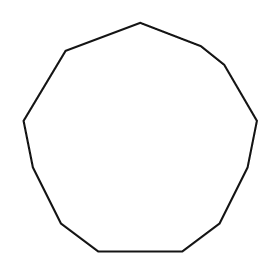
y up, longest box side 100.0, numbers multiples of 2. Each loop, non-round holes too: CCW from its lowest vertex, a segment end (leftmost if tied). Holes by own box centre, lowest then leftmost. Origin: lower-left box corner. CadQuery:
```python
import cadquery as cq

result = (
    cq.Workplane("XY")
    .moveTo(32.0, 0.0)
    .lineTo(68.0, 0.0)
    .lineTo(84.0, 12.0)
    .lineTo(96.0, 36.0)
    .lineTo(100.0, 56.0)
    .lineTo(86.0, 80.0)
    .lineTo(76.0, 88.0)
    .lineTo(50.0, 98.0)
    .lineTo(18.0, 86.0)
    .lineTo(0.0, 56.0)
    .lineTo(4.0, 36.0)
    .lineTo(16.0, 12.0)
    .close()
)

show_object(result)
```